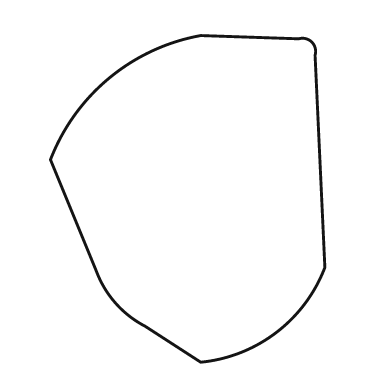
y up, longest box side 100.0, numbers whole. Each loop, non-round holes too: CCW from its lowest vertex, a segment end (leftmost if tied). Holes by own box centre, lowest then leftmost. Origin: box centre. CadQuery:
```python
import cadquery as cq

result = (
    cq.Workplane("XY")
    .moveTo(4.0, -50.0)
    .threePointArc((27.0, -41.0), (42.0, -21.0))
    .lineTo(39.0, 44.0)
    .threePointArc((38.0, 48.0), (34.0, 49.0))
    .lineTo(4.0, 50.0)
    .threePointArc((-24.0, 37.0), (-42.0, 12.0))
    .lineTo(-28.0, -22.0)
    .threePointArc((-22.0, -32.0), (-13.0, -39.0))
    .close()
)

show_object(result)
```